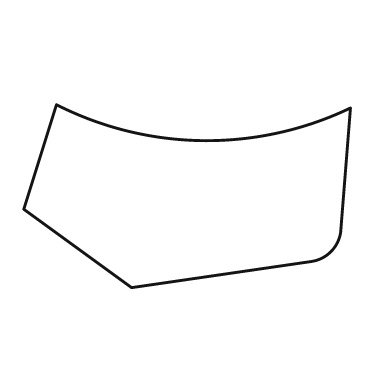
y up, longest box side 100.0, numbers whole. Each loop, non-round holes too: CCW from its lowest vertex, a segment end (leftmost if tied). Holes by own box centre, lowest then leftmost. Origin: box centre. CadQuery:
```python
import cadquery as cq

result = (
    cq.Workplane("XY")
    .moveTo(-17.0, -28.0)
    .lineTo(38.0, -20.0)
    .threePointArc((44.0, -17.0), (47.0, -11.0))
    .lineTo(50.0, 27.0)
    .threePointArc((5.0, 17.0), (-40.0, 28.0))
    .lineTo(-50.0, -4.0)
    .close()
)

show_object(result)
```